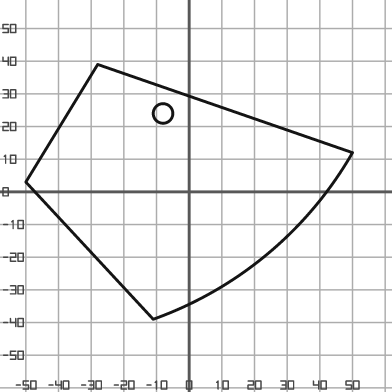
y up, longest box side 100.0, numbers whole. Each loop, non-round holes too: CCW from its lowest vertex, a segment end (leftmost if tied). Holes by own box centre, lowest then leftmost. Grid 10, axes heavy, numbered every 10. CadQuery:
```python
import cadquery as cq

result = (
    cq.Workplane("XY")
    .moveTo(-11.0, -39.0)
    .threePointArc((24.0, -19.0), (50.0, 12.0))
    .lineTo(-28.0, 39.0)
    .lineTo(-50.0, 3.0)
    .close()
    .moveTo(-8.0, 24.0)
    .circle(3.0)
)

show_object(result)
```